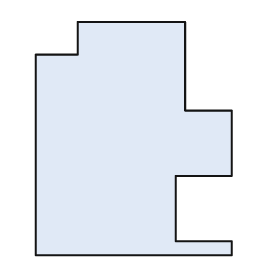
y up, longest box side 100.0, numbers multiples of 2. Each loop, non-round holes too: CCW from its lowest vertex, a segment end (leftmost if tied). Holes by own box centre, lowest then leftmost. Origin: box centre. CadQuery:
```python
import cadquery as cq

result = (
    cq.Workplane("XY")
    .moveTo(-42.0, -50.0)
    .lineTo(42.0, -50.0)
    .lineTo(42.0, -44.0)
    .lineTo(18.0, -44.0)
    .lineTo(18.0, -16.0)
    .lineTo(42.0, -16.0)
    .lineTo(42.0, 12.0)
    .lineTo(22.0, 12.0)
    .lineTo(22.0, 50.0)
    .lineTo(-24.0, 50.0)
    .lineTo(-24.0, 36.0)
    .lineTo(-42.0, 36.0)
    .close()
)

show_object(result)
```